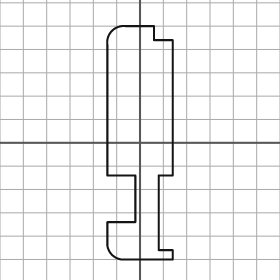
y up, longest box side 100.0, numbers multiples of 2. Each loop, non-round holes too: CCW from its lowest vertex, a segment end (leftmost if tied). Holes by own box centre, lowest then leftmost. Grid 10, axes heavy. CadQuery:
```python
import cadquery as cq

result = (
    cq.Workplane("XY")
    .moveTo(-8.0, -50.0)
    .lineTo(14.0, -50.0)
    .lineTo(14.0, -46.0)
    .lineTo(8.0, -46.0)
    .lineTo(8.0, -14.0)
    .lineTo(14.0, -14.0)
    .lineTo(14.0, 44.0)
    .lineTo(6.0, 44.0)
    .lineTo(6.0, 50.0)
    .lineTo(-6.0, 50.0)
    .threePointArc((-12.0, 48.0), (-14.0, 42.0))
    .lineTo(-14.0, -14.0)
    .lineTo(-2.0, -14.0)
    .lineTo(-2.0, -34.0)
    .lineTo(-14.0, -34.0)
    .lineTo(-14.0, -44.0)
    .threePointArc((-12.0, -48.0), (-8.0, -50.0))
    .close()
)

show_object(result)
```